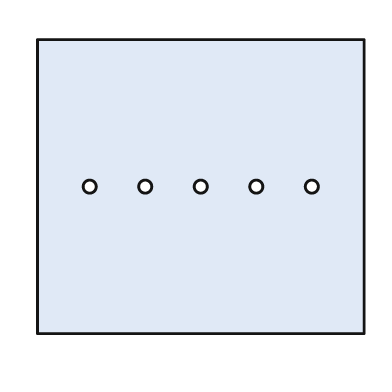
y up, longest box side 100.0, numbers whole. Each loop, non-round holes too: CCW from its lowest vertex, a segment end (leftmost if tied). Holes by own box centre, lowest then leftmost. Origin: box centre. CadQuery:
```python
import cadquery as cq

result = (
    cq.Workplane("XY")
    .moveTo(-50.0, -45.0)
    .lineTo(50.0, -45.0)
    .lineTo(50.0, 45.0)
    .lineTo(-50.0, 45.0)
    .close()
    .moveTo(-34.0, 0.0)
    .circle(2.0)
    .moveTo(-17.0, 0.0)
    .circle(2.0)
    .moveTo(0.0, 0.0)
    .circle(2.0)
    .moveTo(17.0, 0.0)
    .circle(2.0)
    .moveTo(34.0, 0.0)
    .circle(2.0)
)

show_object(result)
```